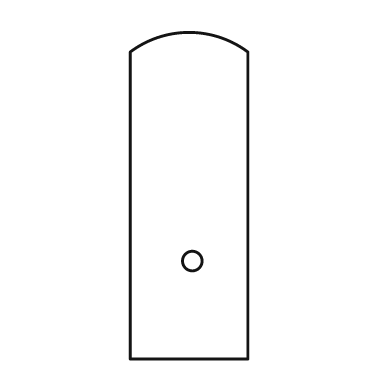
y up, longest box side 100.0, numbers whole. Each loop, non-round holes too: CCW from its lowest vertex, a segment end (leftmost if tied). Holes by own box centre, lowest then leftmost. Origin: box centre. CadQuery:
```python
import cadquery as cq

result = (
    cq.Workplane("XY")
    .moveTo(-18.0, -50.0)
    .lineTo(18.0, -50.0)
    .lineTo(18.0, 44.0)
    .threePointArc((0.0, 50.0), (-18.0, 44.0))
    .close()
    .moveTo(1.0, -20.0)
    .circle(3.0)
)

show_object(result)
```